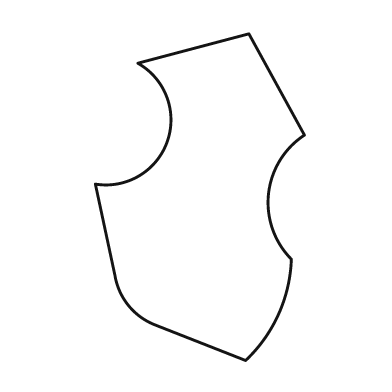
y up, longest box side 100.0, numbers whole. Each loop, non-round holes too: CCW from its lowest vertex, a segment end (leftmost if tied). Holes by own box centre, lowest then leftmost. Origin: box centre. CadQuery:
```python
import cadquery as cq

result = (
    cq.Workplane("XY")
    .moveTo(14.0, -50.0)
    .threePointArc((24.0, -36.0), (28.0, -19.0))
    .threePointArc((21.0, 1.0), (32.0, 19.0))
    .lineTo(15.0, 50.0)
    .lineTo(-19.0, 41.0)
    .threePointArc((-10.0, 17.0), (-32.0, 4.0))
    .lineTo(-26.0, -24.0)
    .threePointArc((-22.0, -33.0), (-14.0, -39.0))
    .close()
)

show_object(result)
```